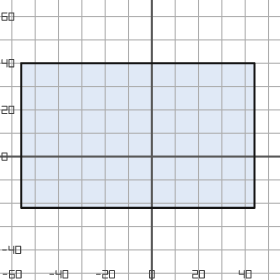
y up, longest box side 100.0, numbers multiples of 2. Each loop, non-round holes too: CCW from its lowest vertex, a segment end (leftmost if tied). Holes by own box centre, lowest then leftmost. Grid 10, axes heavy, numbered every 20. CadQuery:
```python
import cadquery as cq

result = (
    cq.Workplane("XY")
    .moveTo(-56.0, -22.0)
    .lineTo(44.0, -22.0)
    .lineTo(44.0, 40.0)
    .lineTo(-56.0, 40.0)
    .close()
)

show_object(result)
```